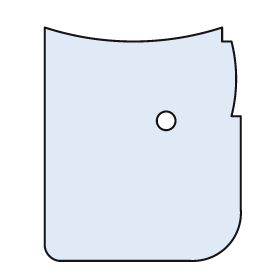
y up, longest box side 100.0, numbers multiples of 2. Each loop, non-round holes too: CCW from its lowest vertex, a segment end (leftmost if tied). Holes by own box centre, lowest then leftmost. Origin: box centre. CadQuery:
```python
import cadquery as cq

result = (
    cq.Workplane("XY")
    .moveTo(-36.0, -50.0)
    .lineTo(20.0, -50.0)
    .threePointArc((36.0, -44.0), (42.0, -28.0))
    .lineTo(42.0, 12.0)
    .lineTo(38.0, 12.0)
    .threePointArc((40.0, 28.0), (38.0, 44.0))
    .lineTo(34.0, 44.0)
    .lineTo(34.0, 50.0)
    .threePointArc((-4.0, 44.0), (-42.0, 50.0))
    .lineTo(-42.0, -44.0)
    .threePointArc((-40.0, -48.0), (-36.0, -50.0))
    .close()
    .moveTo(10.0, 10.0)
    .circle(4.0)
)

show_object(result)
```